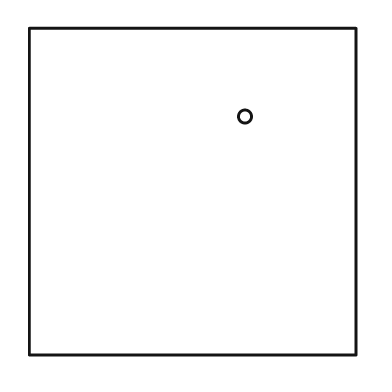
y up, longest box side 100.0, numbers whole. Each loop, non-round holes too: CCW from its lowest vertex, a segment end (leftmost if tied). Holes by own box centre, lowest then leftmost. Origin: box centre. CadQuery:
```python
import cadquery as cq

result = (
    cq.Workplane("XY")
    .moveTo(-50.0, -50.0)
    .lineTo(50.0, -50.0)
    .lineTo(50.0, 50.0)
    .lineTo(-50.0, 50.0)
    .close()
    .moveTo(16.0, 23.0)
    .circle(2.0)
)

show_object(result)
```